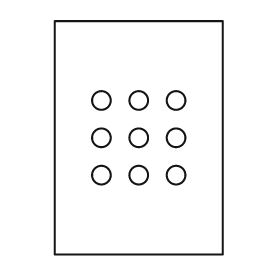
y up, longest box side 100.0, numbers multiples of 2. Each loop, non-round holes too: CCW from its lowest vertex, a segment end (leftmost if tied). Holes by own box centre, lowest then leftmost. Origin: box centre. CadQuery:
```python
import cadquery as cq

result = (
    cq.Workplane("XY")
    .moveTo(-36.0, -50.0)
    .lineTo(36.0, -50.0)
    .lineTo(36.0, 50.0)
    .lineTo(-36.0, 50.0)
    .close()
    .moveTo(-16.0, -16.0)
    .circle(4.0)
    .moveTo(0.0, -16.0)
    .circle(4.0)
    .moveTo(16.0, -16.0)
    .circle(4.0)
    .moveTo(-16.0, 0.0)
    .circle(4.0)
    .moveTo(0.0, 0.0)
    .circle(4.0)
    .moveTo(16.0, 0.0)
    .circle(4.0)
    .moveTo(-16.0, 16.0)
    .circle(4.0)
    .moveTo(0.0, 16.0)
    .circle(4.0)
    .moveTo(16.0, 16.0)
    .circle(4.0)
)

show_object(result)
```